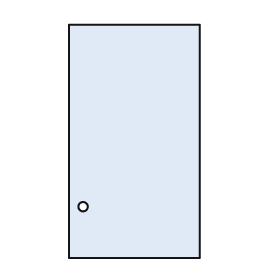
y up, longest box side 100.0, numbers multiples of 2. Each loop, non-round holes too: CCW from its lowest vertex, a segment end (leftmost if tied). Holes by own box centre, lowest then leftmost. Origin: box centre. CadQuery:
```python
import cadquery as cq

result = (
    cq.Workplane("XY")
    .moveTo(-28.0, -50.0)
    .lineTo(28.0, -50.0)
    .lineTo(28.0, 50.0)
    .lineTo(-28.0, 50.0)
    .close()
    .moveTo(-22.0, -28.0)
    .circle(2.0)
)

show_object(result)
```